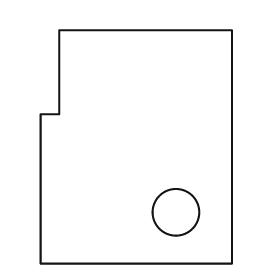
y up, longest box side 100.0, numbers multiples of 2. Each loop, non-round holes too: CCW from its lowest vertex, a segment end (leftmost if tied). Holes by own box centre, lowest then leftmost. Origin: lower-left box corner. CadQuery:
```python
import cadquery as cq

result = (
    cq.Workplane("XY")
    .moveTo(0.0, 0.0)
    .lineTo(82.0, 0.0)
    .lineTo(82.0, 100.0)
    .lineTo(8.0, 100.0)
    .lineTo(8.0, 64.0)
    .lineTo(0.0, 64.0)
    .close()
    .moveTo(58.0, 22.0)
    .circle(10.0)
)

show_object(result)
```